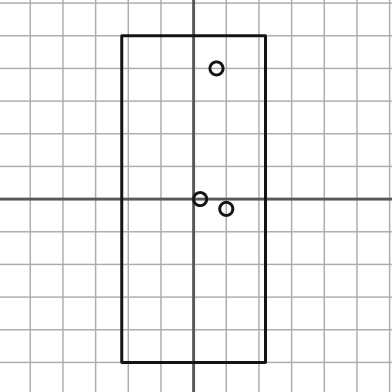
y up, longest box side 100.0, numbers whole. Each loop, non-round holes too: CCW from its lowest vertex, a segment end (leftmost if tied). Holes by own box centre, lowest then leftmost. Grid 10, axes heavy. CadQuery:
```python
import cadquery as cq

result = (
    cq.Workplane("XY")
    .moveTo(-22.0, -50.0)
    .lineTo(22.0, -50.0)
    .lineTo(22.0, 50.0)
    .lineTo(-22.0, 50.0)
    .close()
    .moveTo(10.0, -3.0)
    .circle(2.0)
    .moveTo(2.0, 0.0)
    .circle(2.0)
    .moveTo(7.0, 40.0)
    .circle(2.0)
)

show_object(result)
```